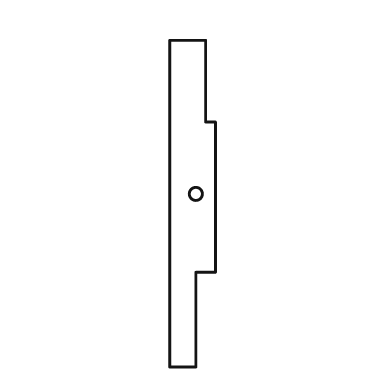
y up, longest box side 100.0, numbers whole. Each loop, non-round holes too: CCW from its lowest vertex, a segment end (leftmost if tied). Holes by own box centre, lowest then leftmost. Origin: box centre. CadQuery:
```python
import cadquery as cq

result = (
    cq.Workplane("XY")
    .moveTo(-7.0, -50.0)
    .lineTo(1.0, -50.0)
    .lineTo(1.0, -21.0)
    .lineTo(7.0, -21.0)
    .lineTo(7.0, 25.0)
    .lineTo(4.0, 25.0)
    .lineTo(4.0, 50.0)
    .lineTo(-7.0, 50.0)
    .close()
    .moveTo(1.0, 3.0)
    .circle(2.0)
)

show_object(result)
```